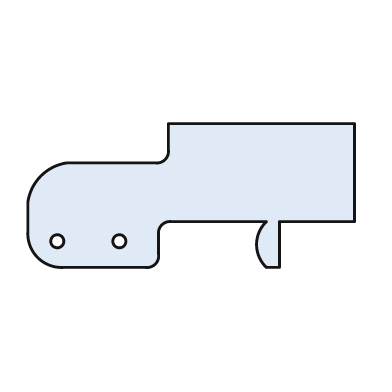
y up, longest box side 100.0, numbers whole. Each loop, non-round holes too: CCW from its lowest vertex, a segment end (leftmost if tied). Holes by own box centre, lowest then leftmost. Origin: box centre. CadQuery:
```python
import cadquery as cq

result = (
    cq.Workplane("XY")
    .moveTo(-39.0, -22.0)
    .lineTo(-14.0, -22.0)
    .threePointArc((-11.0, -21.0), (-10.0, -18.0))
    .lineTo(-10.0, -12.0)
    .threePointArc((-9.0, -9.0), (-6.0, -8.0))
    .lineTo(23.0, -8.0)
    .threePointArc((20.0, -15.0), (23.0, -22.0))
    .lineTo(27.0, -22.0)
    .lineTo(27.0, -8.0)
    .lineTo(50.0, -8.0)
    .lineTo(50.0, 22.0)
    .lineTo(-7.0, 22.0)
    .lineTo(-7.0, 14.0)
    .threePointArc((-8.0, 11.0), (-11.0, 10.0))
    .lineTo(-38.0, 10.0)
    .threePointArc((-46.0, 6.0), (-50.0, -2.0))
    .lineTo(-50.0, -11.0)
    .threePointArc((-47.0, -19.0), (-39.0, -22.0))
    .close()
    .moveTo(-41.0, -14.0)
    .circle(2.0)
    .moveTo(-22.0, -14.0)
    .circle(2.0)
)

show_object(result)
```